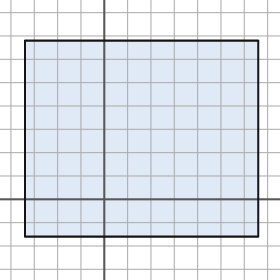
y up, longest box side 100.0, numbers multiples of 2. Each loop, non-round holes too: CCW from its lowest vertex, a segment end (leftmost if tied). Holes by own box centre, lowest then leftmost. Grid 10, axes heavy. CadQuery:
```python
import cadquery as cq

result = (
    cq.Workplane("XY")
    .moveTo(-34.0, -16.0)
    .lineTo(66.0, -16.0)
    .lineTo(66.0, 68.0)
    .lineTo(-34.0, 68.0)
    .close()
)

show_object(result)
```